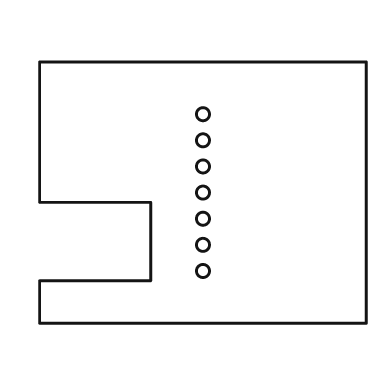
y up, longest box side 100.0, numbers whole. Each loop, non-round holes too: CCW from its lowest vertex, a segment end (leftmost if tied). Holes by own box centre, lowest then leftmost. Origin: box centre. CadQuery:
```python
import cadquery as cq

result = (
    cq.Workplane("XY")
    .moveTo(-50.0, -40.0)
    .lineTo(50.0, -40.0)
    .lineTo(50.0, 40.0)
    .lineTo(-50.0, 40.0)
    .lineTo(-50.0, -3.0)
    .lineTo(-16.0, -3.0)
    .lineTo(-16.0, -27.0)
    .lineTo(-50.0, -27.0)
    .close()
    .moveTo(0.0, -24.0)
    .circle(2.0)
    .moveTo(0.0, -16.0)
    .circle(2.0)
    .moveTo(0.0, -8.0)
    .circle(2.0)
    .moveTo(0.0, 0.0)
    .circle(2.0)
    .moveTo(0.0, 8.0)
    .circle(2.0)
    .moveTo(0.0, 16.0)
    .circle(2.0)
    .moveTo(0.0, 24.0)
    .circle(2.0)
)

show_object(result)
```